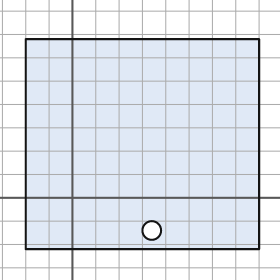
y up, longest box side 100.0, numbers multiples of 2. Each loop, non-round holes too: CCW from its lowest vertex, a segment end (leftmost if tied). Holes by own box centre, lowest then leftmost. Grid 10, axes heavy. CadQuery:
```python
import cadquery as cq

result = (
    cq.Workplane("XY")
    .moveTo(-20.0, -22.0)
    .lineTo(80.0, -22.0)
    .lineTo(80.0, 68.0)
    .lineTo(-20.0, 68.0)
    .close()
    .moveTo(34.0, -14.0)
    .circle(4.0)
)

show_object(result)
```